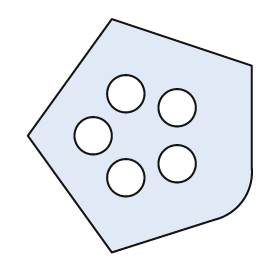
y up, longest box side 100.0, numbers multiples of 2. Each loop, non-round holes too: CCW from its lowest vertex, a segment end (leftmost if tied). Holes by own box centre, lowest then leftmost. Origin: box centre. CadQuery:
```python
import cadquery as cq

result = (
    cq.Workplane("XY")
    .moveTo(-12.0, -50.0)
    .lineTo(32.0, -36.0)
    .threePointArc((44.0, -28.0), (48.0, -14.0))
    .lineTo(48.0, 30.0)
    .lineTo(-12.0, 50.0)
    .lineTo(-48.0, 0.0)
    .close()
    .moveTo(-6.0, -18.0)
    .circle(8.0)
    .moveTo(16.0, -12.0)
    .circle(8.0)
    .moveTo(-20.0, 0.0)
    .circle(8.0)
    .moveTo(16.0, 12.0)
    .circle(8.0)
    .moveTo(-6.0, 18.0)
    .circle(8.0)
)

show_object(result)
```